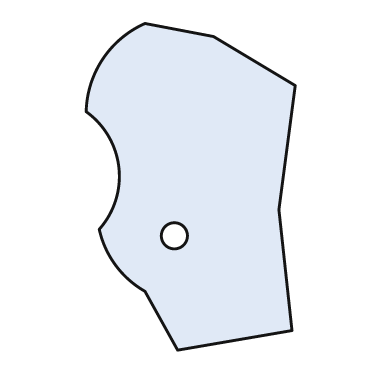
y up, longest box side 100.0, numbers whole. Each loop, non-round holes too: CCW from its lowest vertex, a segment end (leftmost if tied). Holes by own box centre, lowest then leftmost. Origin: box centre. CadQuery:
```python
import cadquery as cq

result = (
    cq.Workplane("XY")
    .moveTo(-4.0, -50.0)
    .lineTo(31.0, -44.0)
    .lineTo(27.0, -7.0)
    .lineTo(32.0, 31.0)
    .lineTo(7.0, 46.0)
    .lineTo(-14.0, 50.0)
    .threePointArc((-27.0, 39.0), (-32.0, 23.0))
    .threePointArc((-22.0, 6.0), (-28.0, -13.0))
    .threePointArc((-23.0, -24.0), (-14.0, -32.0))
    .close()
    .moveTo(-5.0, -15.0)
    .circle(4.0)
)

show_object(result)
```